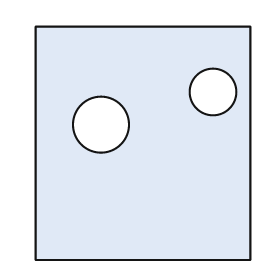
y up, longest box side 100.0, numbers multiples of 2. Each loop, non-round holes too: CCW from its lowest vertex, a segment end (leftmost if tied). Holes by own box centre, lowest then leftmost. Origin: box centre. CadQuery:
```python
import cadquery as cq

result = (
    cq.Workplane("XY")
    .moveTo(-46.0, -50.0)
    .lineTo(46.0, -50.0)
    .lineTo(46.0, 50.0)
    .lineTo(-46.0, 50.0)
    .close()
    .moveTo(-18.0, 8.0)
    .circle(12.0)
    .moveTo(30.0, 22.0)
    .circle(10.0)
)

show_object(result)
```